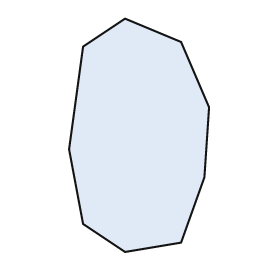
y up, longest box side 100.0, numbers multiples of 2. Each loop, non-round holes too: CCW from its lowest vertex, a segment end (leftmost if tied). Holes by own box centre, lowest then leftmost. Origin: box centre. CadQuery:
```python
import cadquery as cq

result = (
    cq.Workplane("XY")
    .moveTo(-6.0, -50.0)
    .lineTo(18.0, -46.0)
    .lineTo(28.0, -18.0)
    .lineTo(30.0, 12.0)
    .lineTo(18.0, 40.0)
    .lineTo(-6.0, 50.0)
    .lineTo(-24.0, 38.0)
    .lineTo(-30.0, -6.0)
    .lineTo(-24.0, -38.0)
    .close()
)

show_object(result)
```